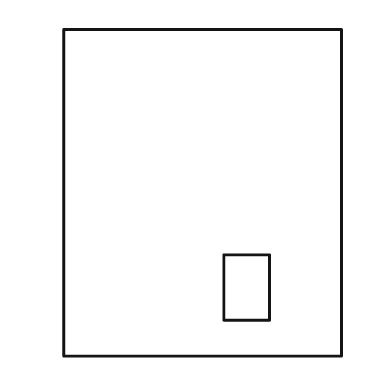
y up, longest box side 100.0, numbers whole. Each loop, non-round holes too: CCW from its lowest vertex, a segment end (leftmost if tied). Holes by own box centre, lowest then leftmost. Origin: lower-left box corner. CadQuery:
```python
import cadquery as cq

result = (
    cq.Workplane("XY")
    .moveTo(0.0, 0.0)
    .lineTo(85.0, 0.0)
    .lineTo(85.0, 100.0)
    .lineTo(0.0, 100.0)
    .close()
    .moveTo(49.0, 11.0)
    .lineTo(63.0, 11.0)
    .lineTo(63.0, 31.0)
    .lineTo(49.0, 31.0)
    .close()
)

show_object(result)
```